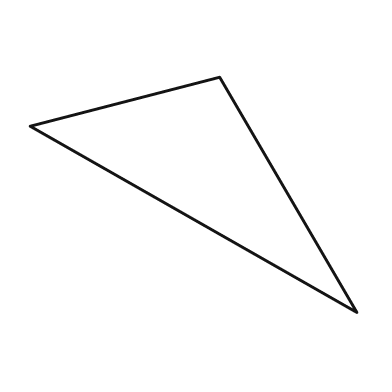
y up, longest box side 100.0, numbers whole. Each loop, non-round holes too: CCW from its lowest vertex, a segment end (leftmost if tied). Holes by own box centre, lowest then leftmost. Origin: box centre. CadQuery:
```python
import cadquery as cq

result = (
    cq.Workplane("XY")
    .moveTo(50.0, -36.0)
    .lineTo(8.0, 36.0)
    .lineTo(-50.0, 21.0)
    .close()
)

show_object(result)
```